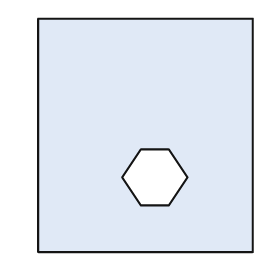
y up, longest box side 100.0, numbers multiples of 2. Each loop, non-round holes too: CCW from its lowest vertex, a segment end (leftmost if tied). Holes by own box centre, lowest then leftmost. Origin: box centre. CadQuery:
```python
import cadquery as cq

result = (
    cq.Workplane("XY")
    .moveTo(-46.0, -50.0)
    .lineTo(46.0, -50.0)
    .lineTo(46.0, 50.0)
    .lineTo(-46.0, 50.0)
    .close()
    .moveTo(-2.0, -30.0)
    .lineTo(10.0, -30.0)
    .lineTo(18.0, -18.0)
    .lineTo(10.0, -6.0)
    .lineTo(-2.0, -6.0)
    .lineTo(-10.0, -18.0)
    .close()
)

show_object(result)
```